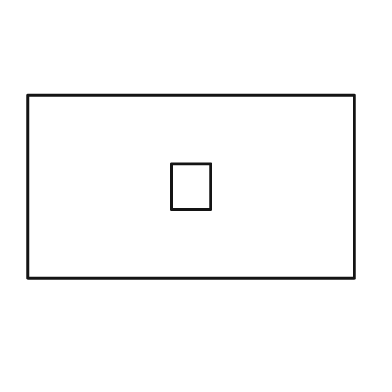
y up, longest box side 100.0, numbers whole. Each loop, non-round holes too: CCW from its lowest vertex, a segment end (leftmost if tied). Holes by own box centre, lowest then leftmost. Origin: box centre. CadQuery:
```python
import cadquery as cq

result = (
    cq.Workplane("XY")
    .moveTo(-50.0, -28.0)
    .lineTo(50.0, -28.0)
    .lineTo(50.0, 28.0)
    .lineTo(-50.0, 28.0)
    .close()
    .moveTo(-6.0, -7.0)
    .lineTo(6.0, -7.0)
    .lineTo(6.0, 7.0)
    .lineTo(-6.0, 7.0)
    .close()
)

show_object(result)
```